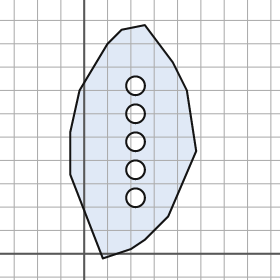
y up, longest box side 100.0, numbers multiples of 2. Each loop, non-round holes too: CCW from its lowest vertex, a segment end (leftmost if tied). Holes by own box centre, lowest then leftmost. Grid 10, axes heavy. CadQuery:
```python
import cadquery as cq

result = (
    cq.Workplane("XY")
    .moveTo(8.0, -2.0)
    .lineTo(20.0, 2.0)
    .lineTo(26.0, 6.0)
    .lineTo(36.0, 16.0)
    .lineTo(48.0, 44.0)
    .lineTo(44.0, 70.0)
    .lineTo(38.0, 82.0)
    .lineTo(26.0, 98.0)
    .lineTo(16.0, 96.0)
    .lineTo(10.0, 90.0)
    .lineTo(-2.0, 70.0)
    .lineTo(-6.0, 52.0)
    .lineTo(-6.0, 34.0)
    .close()
    .moveTo(22.0, 24.0)
    .circle(4.0)
    .moveTo(22.0, 36.0)
    .circle(4.0)
    .moveTo(22.0, 48.0)
    .circle(4.0)
    .moveTo(22.0, 60.0)
    .circle(4.0)
    .moveTo(22.0, 72.0)
    .circle(4.0)
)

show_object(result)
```